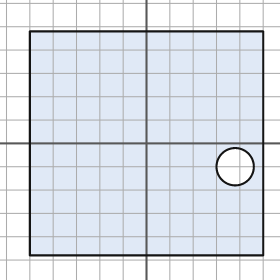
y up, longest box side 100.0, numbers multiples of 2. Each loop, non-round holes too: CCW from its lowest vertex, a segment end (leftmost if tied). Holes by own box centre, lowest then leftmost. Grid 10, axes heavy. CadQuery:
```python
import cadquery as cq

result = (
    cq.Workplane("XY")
    .moveTo(-50.0, -48.0)
    .lineTo(50.0, -48.0)
    .lineTo(50.0, 48.0)
    .lineTo(-50.0, 48.0)
    .close()
    .moveTo(38.0, -10.0)
    .circle(8.0)
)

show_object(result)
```